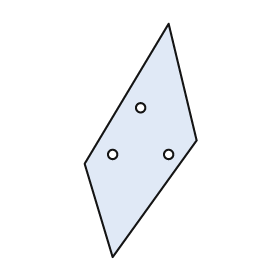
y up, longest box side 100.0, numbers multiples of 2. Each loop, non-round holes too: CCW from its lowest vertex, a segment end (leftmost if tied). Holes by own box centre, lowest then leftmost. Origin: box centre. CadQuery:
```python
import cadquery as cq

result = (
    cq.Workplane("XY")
    .moveTo(-12.0, -50.0)
    .lineTo(24.0, 0.0)
    .lineTo(12.0, 50.0)
    .lineTo(-24.0, -10.0)
    .close()
    .moveTo(-12.0, -6.0)
    .circle(2.0)
    .moveTo(12.0, -6.0)
    .circle(2.0)
    .moveTo(0.0, 14.0)
    .circle(2.0)
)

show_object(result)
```